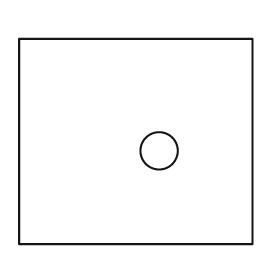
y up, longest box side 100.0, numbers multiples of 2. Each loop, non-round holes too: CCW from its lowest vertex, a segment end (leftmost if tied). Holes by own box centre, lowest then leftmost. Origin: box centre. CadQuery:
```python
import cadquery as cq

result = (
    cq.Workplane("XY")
    .moveTo(-50.0, -44.0)
    .lineTo(50.0, -44.0)
    .lineTo(50.0, 44.0)
    .lineTo(-50.0, 44.0)
    .close()
    .moveTo(10.0, -4.0)
    .circle(8.0)
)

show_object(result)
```